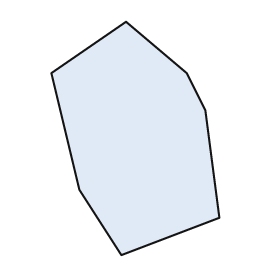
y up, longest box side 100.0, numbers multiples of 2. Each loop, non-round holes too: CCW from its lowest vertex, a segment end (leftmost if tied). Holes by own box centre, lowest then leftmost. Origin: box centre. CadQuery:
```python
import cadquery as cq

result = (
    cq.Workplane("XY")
    .moveTo(-6.0, -50.0)
    .lineTo(36.0, -34.0)
    .lineTo(30.0, 12.0)
    .lineTo(22.0, 28.0)
    .lineTo(-4.0, 50.0)
    .lineTo(-36.0, 28.0)
    .lineTo(-24.0, -22.0)
    .close()
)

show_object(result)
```